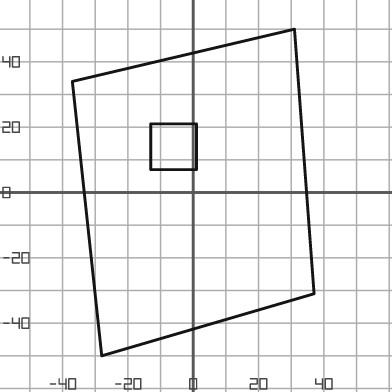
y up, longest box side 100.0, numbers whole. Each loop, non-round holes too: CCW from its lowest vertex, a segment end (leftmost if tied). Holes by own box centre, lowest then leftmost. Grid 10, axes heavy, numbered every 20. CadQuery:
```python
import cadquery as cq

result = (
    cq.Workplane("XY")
    .moveTo(-28.0, -50.0)
    .lineTo(37.0, -31.0)
    .lineTo(31.0, 50.0)
    .lineTo(-37.0, 34.0)
    .close()
    .moveTo(-13.0, 7.0)
    .lineTo(1.0, 7.0)
    .lineTo(1.0, 21.0)
    .lineTo(-13.0, 21.0)
    .close()
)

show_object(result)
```